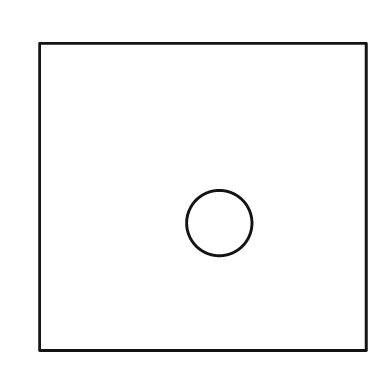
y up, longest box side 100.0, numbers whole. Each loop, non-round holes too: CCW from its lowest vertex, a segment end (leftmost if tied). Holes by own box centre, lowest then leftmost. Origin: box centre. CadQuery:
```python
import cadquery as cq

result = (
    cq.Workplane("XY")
    .moveTo(-50.0, -47.0)
    .lineTo(50.0, -47.0)
    .lineTo(50.0, 47.0)
    .lineTo(-50.0, 47.0)
    .close()
    .moveTo(5.0, -8.0)
    .circle(10.0)
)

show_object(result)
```